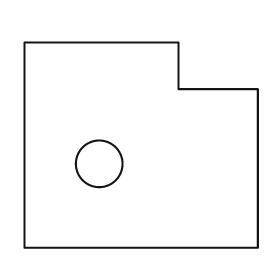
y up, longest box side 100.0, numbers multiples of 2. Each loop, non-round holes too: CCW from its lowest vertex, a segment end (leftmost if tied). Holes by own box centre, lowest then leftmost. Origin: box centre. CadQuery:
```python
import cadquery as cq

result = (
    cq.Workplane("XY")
    .moveTo(-50.0, -44.0)
    .lineTo(50.0, -44.0)
    .lineTo(50.0, 24.0)
    .lineTo(16.0, 24.0)
    .lineTo(16.0, 44.0)
    .lineTo(-50.0, 44.0)
    .close()
    .moveTo(-18.0, -8.0)
    .circle(10.0)
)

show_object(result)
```